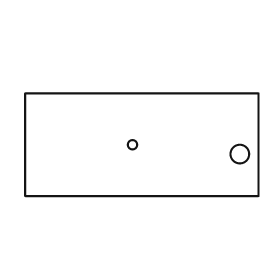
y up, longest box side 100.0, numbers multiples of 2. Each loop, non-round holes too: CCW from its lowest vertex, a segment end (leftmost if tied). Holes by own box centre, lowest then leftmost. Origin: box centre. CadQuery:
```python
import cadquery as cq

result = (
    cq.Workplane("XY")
    .moveTo(-50.0, -22.0)
    .lineTo(50.0, -22.0)
    .lineTo(50.0, 22.0)
    .lineTo(-50.0, 22.0)
    .close()
    .moveTo(42.0, -4.0)
    .circle(4.0)
    .moveTo(-4.0, 0.0)
    .circle(2.0)
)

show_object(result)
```